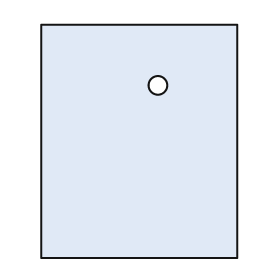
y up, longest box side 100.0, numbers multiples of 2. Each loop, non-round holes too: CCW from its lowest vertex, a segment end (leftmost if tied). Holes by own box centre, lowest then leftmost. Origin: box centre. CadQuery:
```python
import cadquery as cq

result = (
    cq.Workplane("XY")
    .moveTo(-42.0, -50.0)
    .lineTo(42.0, -50.0)
    .lineTo(42.0, 50.0)
    .lineTo(-42.0, 50.0)
    .close()
    .moveTo(8.0, 24.0)
    .circle(4.0)
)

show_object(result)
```